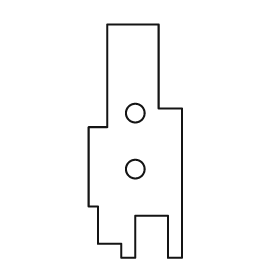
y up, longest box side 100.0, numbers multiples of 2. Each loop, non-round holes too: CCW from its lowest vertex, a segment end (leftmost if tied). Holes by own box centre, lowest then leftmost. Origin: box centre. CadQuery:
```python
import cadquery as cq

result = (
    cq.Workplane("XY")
    .moveTo(-6.0, -50.0)
    .lineTo(0.0, -50.0)
    .lineTo(0.0, -32.0)
    .lineTo(14.0, -32.0)
    .lineTo(14.0, -50.0)
    .lineTo(20.0, -50.0)
    .lineTo(20.0, 14.0)
    .lineTo(10.0, 14.0)
    .lineTo(10.0, 50.0)
    .lineTo(-12.0, 50.0)
    .lineTo(-12.0, 6.0)
    .lineTo(-20.0, 6.0)
    .lineTo(-20.0, -28.0)
    .lineTo(-16.0, -28.0)
    .lineTo(-16.0, -44.0)
    .lineTo(-6.0, -44.0)
    .close()
    .moveTo(0.0, -12.0)
    .circle(4.0)
    .moveTo(0.0, 12.0)
    .circle(4.0)
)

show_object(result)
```